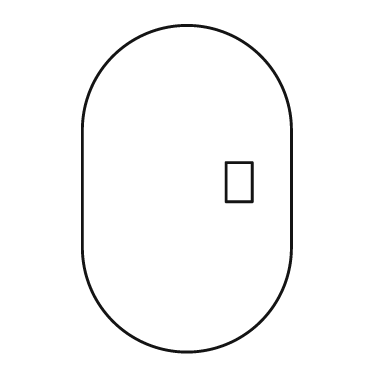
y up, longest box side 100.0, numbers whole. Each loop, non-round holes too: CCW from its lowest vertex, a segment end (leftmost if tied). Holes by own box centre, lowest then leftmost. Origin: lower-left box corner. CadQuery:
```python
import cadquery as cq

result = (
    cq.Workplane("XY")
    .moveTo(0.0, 32.0)
    .threePointArc((32.0, 0.0), (64.0, 32.0))
    .lineTo(64.0, 68.0)
    .threePointArc((32.0, 100.0), (0.0, 68.0))
    .close()
    .moveTo(44.0, 46.0)
    .lineTo(52.0, 46.0)
    .lineTo(52.0, 58.0)
    .lineTo(44.0, 58.0)
    .close()
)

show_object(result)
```